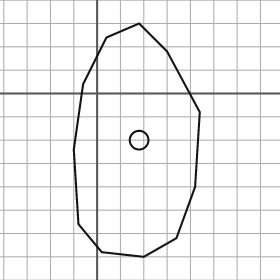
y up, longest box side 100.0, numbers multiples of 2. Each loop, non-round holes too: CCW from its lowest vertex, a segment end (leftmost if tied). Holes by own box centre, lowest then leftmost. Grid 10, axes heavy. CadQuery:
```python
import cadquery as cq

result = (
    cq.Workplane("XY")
    .moveTo(20.0, -70.0)
    .lineTo(34.0, -62.0)
    .lineTo(42.0, -40.0)
    .lineTo(44.0, -8.0)
    .lineTo(30.0, 18.0)
    .lineTo(18.0, 30.0)
    .lineTo(4.0, 24.0)
    .lineTo(-6.0, 4.0)
    .lineTo(-10.0, -24.0)
    .lineTo(-8.0, -56.0)
    .lineTo(2.0, -68.0)
    .close()
    .moveTo(18.0, -20.0)
    .circle(4.0)
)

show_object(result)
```